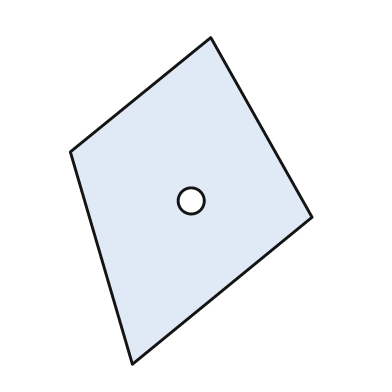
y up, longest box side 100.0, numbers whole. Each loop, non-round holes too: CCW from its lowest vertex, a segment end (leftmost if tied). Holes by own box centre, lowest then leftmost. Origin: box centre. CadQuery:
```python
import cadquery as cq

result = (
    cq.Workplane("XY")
    .moveTo(-18.0, -50.0)
    .lineTo(37.0, -5.0)
    .lineTo(6.0, 50.0)
    .lineTo(-37.0, 15.0)
    .close()
    .moveTo(0.0, 0.0)
    .circle(4.0)
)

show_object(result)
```